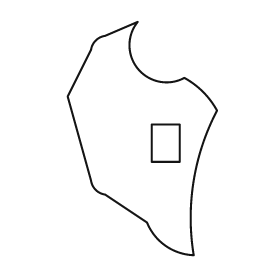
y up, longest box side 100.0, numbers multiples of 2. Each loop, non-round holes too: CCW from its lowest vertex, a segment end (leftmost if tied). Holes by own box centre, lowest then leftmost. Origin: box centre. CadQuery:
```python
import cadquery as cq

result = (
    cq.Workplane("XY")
    .moveTo(22.0, -50.0)
    .threePointArc((22.0, -18.0), (32.0, 12.0))
    .threePointArc((26.0, 20.0), (18.0, 26.0))
    .threePointArc((-2.0, 30.0), (-2.0, 50.0))
    .lineTo(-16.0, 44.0)
    .threePointArc((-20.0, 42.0), (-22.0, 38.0))
    .lineTo(-32.0, 18.0)
    .lineTo(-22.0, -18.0)
    .threePointArc((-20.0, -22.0), (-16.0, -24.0))
    .lineTo(2.0, -36.0)
    .threePointArc((10.0, -46.0), (22.0, -50.0))
    .close()
    .moveTo(4.0, -10.0)
    .lineTo(16.0, -10.0)
    .lineTo(16.0, 6.0)
    .lineTo(4.0, 6.0)
    .close()
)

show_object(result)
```